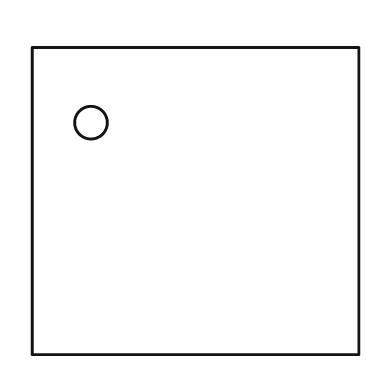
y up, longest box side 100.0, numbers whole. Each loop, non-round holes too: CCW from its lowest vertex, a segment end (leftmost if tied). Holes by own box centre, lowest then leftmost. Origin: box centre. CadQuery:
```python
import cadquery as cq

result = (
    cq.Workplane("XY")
    .moveTo(-50.0, -47.0)
    .lineTo(50.0, -47.0)
    .lineTo(50.0, 47.0)
    .lineTo(-50.0, 47.0)
    .close()
    .moveTo(-32.0, 24.0)
    .circle(5.0)
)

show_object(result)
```